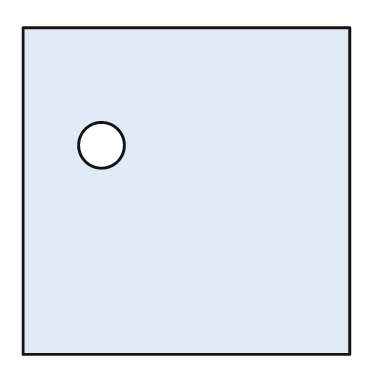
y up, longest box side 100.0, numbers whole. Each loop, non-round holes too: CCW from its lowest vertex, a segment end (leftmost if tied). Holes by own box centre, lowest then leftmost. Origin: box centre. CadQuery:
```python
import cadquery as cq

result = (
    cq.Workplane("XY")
    .moveTo(-50.0, -50.0)
    .lineTo(50.0, -50.0)
    .lineTo(50.0, 50.0)
    .lineTo(-50.0, 50.0)
    .close()
    .moveTo(-26.0, 14.0)
    .circle(7.0)
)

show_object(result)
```